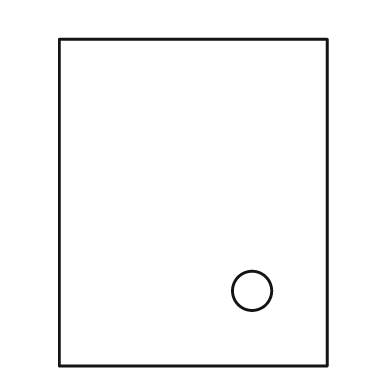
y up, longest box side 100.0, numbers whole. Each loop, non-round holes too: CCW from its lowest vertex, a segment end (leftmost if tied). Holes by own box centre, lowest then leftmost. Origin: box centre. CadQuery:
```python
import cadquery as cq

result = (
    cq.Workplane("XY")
    .moveTo(-41.0, -50.0)
    .lineTo(41.0, -50.0)
    .lineTo(41.0, 50.0)
    .lineTo(-41.0, 50.0)
    .close()
    .moveTo(18.0, -27.0)
    .circle(6.0)
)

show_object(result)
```